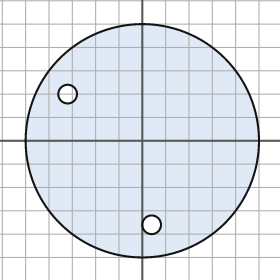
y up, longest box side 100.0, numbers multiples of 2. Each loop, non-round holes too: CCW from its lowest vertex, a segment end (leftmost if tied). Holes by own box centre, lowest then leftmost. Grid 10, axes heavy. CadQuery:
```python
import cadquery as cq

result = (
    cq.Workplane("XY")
    .moveTo(0.0, 0.0)
    .circle(50.0)
    .moveTo(4.0, -36.0)
    .circle(4.0)
    .moveTo(-32.0, 20.0)
    .circle(4.0)
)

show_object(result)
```